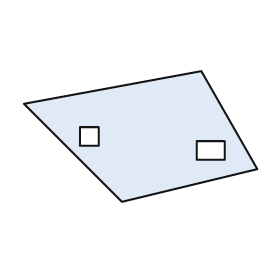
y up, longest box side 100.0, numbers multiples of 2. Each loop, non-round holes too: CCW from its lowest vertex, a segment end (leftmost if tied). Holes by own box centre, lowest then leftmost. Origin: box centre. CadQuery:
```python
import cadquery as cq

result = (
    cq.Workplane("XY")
    .moveTo(-8.0, -28.0)
    .lineTo(50.0, -14.0)
    .lineTo(26.0, 28.0)
    .lineTo(-50.0, 14.0)
    .close()
    .moveTo(24.0, -10.0)
    .lineTo(36.0, -10.0)
    .lineTo(36.0, -2.0)
    .lineTo(24.0, -2.0)
    .close()
    .moveTo(-26.0, -4.0)
    .lineTo(-18.0, -4.0)
    .lineTo(-18.0, 4.0)
    .lineTo(-26.0, 4.0)
    .close()
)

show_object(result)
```